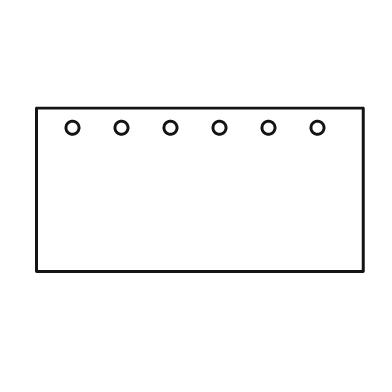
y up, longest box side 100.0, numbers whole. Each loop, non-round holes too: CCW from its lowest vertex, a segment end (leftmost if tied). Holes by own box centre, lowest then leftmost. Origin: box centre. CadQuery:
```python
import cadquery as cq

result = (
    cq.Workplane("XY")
    .moveTo(-50.0, -25.0)
    .lineTo(50.0, -25.0)
    .lineTo(50.0, 25.0)
    .lineTo(-50.0, 25.0)
    .close()
    .moveTo(-39.0, 19.0)
    .circle(2.0)
    .moveTo(-24.0, 19.0)
    .circle(2.0)
    .moveTo(-9.0, 19.0)
    .circle(2.0)
    .moveTo(6.0, 19.0)
    .circle(2.0)
    .moveTo(21.0, 19.0)
    .circle(2.0)
    .moveTo(36.0, 19.0)
    .circle(2.0)
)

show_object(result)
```